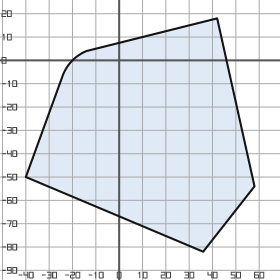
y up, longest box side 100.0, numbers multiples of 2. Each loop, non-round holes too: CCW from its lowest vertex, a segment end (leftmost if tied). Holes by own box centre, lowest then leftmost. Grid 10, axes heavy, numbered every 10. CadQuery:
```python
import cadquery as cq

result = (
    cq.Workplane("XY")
    .moveTo(36.0, -82.0)
    .lineTo(58.0, -54.0)
    .lineTo(42.0, 18.0)
    .lineTo(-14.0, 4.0)
    .threePointArc((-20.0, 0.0), (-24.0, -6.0))
    .lineTo(-40.0, -50.0)
    .close()
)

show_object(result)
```